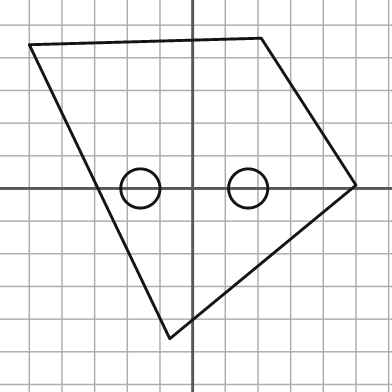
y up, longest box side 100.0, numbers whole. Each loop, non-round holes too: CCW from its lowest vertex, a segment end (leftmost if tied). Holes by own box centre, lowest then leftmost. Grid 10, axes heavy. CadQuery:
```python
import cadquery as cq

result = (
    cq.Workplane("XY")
    .moveTo(-7.0, -46.0)
    .lineTo(50.0, 1.0)
    .lineTo(21.0, 46.0)
    .lineTo(-50.0, 44.0)
    .close()
    .moveTo(-16.0, 0.0)
    .circle(6.0)
    .moveTo(17.0, 0.0)
    .circle(6.0)
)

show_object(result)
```